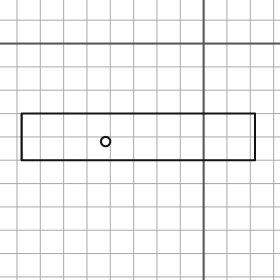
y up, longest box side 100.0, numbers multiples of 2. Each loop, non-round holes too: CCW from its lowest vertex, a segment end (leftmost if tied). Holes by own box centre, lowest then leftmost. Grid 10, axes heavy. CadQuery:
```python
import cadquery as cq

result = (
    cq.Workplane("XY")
    .moveTo(-78.0, -50.0)
    .lineTo(22.0, -50.0)
    .lineTo(22.0, -30.0)
    .lineTo(-78.0, -30.0)
    .close()
    .moveTo(-42.0, -42.0)
    .circle(2.0)
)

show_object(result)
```